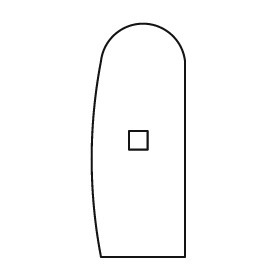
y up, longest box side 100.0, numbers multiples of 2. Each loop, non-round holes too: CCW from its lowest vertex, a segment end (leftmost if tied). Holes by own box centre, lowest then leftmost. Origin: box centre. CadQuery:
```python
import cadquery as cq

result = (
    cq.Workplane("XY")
    .moveTo(-16.0, -50.0)
    .lineTo(20.0, -50.0)
    .lineTo(20.0, 34.0)
    .threePointArc((2.0, 50.0), (-16.0, 34.0))
    .threePointArc((-20.0, -8.0), (-16.0, -50.0))
    .close()
    .moveTo(-4.0, -4.0)
    .lineTo(4.0, -4.0)
    .lineTo(4.0, 4.0)
    .lineTo(-4.0, 4.0)
    .close()
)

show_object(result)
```